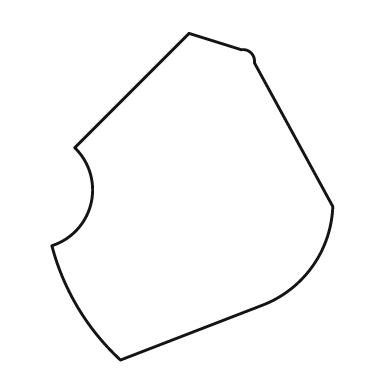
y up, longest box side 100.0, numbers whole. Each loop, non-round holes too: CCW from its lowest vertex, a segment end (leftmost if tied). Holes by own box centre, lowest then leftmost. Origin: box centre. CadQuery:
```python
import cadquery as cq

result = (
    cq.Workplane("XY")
    .moveTo(-22.0, -50.0)
    .lineTo(22.0, -33.0)
    .threePointArc((37.0, -21.0), (43.0, -3.0))
    .lineTo(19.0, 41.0)
    .threePointArc((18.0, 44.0), (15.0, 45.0))
    .lineTo(-1.0, 50.0)
    .lineTo(-36.0, 15.0)
    .threePointArc((-31.0, -2.0), (-43.0, -15.0))
    .threePointArc((-35.0, -34.0), (-22.0, -50.0))
    .close()
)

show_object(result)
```